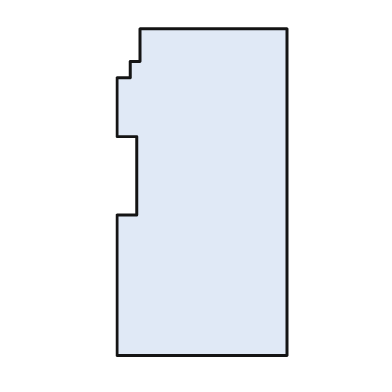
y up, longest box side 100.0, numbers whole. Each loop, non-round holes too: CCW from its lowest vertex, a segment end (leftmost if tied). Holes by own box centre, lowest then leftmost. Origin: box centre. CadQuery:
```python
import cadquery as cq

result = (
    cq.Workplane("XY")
    .moveTo(-26.0, -50.0)
    .lineTo(26.0, -50.0)
    .lineTo(26.0, 50.0)
    .lineTo(-19.0, 50.0)
    .lineTo(-19.0, 40.0)
    .lineTo(-22.0, 40.0)
    .lineTo(-22.0, 35.0)
    .lineTo(-26.0, 35.0)
    .lineTo(-26.0, 17.0)
    .lineTo(-20.0, 17.0)
    .lineTo(-20.0, -7.0)
    .lineTo(-26.0, -7.0)
    .close()
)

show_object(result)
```